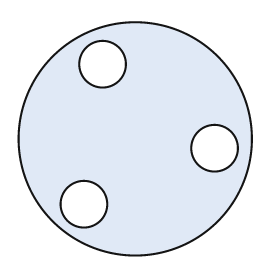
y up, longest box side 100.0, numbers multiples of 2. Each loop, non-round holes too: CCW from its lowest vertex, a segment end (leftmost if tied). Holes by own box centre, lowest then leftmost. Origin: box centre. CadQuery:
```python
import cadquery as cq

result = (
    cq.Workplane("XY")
    .moveTo(0.0, 0.0)
    .circle(50.0)
    .moveTo(-22.0, -28.0)
    .circle(10.0)
    .moveTo(34.0, -4.0)
    .circle(10.0)
    .moveTo(-14.0, 32.0)
    .circle(10.0)
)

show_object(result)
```